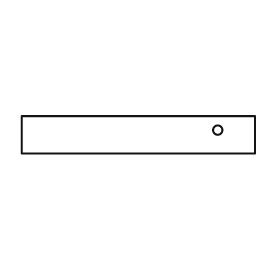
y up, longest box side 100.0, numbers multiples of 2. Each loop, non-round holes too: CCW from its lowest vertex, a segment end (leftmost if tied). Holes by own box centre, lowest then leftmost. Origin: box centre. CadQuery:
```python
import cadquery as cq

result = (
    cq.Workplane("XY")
    .moveTo(-50.0, -8.0)
    .lineTo(50.0, -8.0)
    .lineTo(50.0, 8.0)
    .lineTo(-50.0, 8.0)
    .close()
    .moveTo(34.0, 2.0)
    .circle(2.0)
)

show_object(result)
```